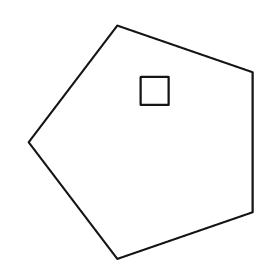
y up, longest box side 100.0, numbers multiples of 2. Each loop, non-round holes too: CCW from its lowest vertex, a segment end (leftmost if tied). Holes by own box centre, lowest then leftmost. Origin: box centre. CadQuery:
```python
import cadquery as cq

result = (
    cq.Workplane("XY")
    .moveTo(-10.0, -50.0)
    .lineTo(48.0, -30.0)
    .lineTo(48.0, 30.0)
    .lineTo(-10.0, 50.0)
    .lineTo(-48.0, 0.0)
    .close()
    .moveTo(0.0, 16.0)
    .lineTo(12.0, 16.0)
    .lineTo(12.0, 28.0)
    .lineTo(0.0, 28.0)
    .close()
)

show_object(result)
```